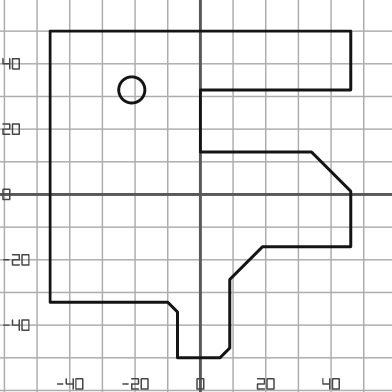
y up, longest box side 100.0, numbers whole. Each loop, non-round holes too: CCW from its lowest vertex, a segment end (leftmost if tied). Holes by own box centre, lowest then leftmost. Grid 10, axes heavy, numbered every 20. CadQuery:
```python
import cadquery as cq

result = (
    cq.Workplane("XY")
    .moveTo(-7.0, -50.0)
    .lineTo(6.0, -50.0)
    .lineTo(9.0, -47.0)
    .lineTo(9.0, -26.0)
    .lineTo(19.0, -16.0)
    .lineTo(46.0, -16.0)
    .lineTo(46.0, 1.0)
    .lineTo(34.0, 13.0)
    .lineTo(0.0, 13.0)
    .lineTo(0.0, 32.0)
    .lineTo(46.0, 32.0)
    .lineTo(46.0, 50.0)
    .lineTo(-46.0, 50.0)
    .lineTo(-46.0, -33.0)
    .lineTo(-10.0, -33.0)
    .lineTo(-7.0, -36.0)
    .close()
    .moveTo(-21.0, 32.0)
    .circle(4.0)
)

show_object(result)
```